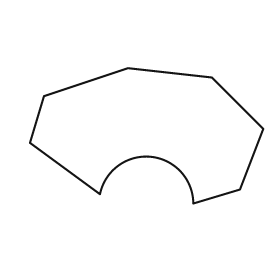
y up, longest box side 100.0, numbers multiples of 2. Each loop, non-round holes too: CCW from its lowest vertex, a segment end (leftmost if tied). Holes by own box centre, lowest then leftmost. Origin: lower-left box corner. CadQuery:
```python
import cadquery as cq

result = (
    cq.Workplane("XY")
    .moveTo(70.0, 0.0)
    .lineTo(90.0, 6.0)
    .lineTo(100.0, 32.0)
    .lineTo(78.0, 54.0)
    .lineTo(42.0, 58.0)
    .lineTo(6.0, 46.0)
    .lineTo(0.0, 26.0)
    .lineTo(30.0, 4.0)
    .threePointArc((52.0, 20.0), (70.0, 0.0))
    .close()
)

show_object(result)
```